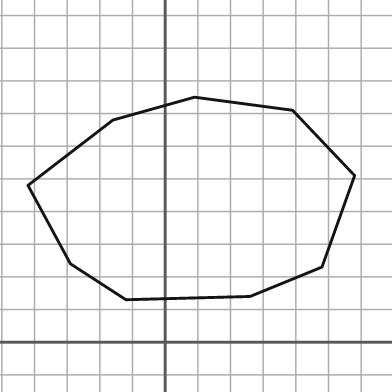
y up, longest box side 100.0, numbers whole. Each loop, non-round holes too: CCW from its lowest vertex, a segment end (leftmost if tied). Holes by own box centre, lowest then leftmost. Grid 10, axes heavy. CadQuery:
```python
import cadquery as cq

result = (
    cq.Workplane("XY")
    .moveTo(-12.0, 13.0)
    .lineTo(26.0, 14.0)
    .lineTo(48.0, 23.0)
    .lineTo(58.0, 51.0)
    .lineTo(39.0, 71.0)
    .lineTo(9.0, 75.0)
    .lineTo(-16.0, 68.0)
    .lineTo(-42.0, 48.0)
    .lineTo(-29.0, 24.0)
    .close()
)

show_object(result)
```